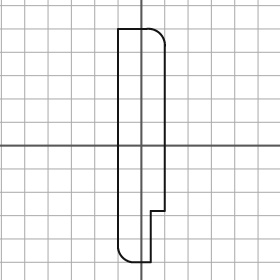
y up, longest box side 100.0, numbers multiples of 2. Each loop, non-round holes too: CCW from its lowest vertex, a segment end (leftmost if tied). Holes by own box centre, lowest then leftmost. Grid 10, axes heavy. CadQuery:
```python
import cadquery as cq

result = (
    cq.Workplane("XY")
    .moveTo(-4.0, -50.0)
    .lineTo(4.0, -50.0)
    .lineTo(4.0, -28.0)
    .lineTo(10.0, -28.0)
    .lineTo(10.0, 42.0)
    .threePointArc((8.0, 48.0), (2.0, 50.0))
    .lineTo(-10.0, 50.0)
    .lineTo(-10.0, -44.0)
    .threePointArc((-8.0, -48.0), (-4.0, -50.0))
    .close()
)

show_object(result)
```